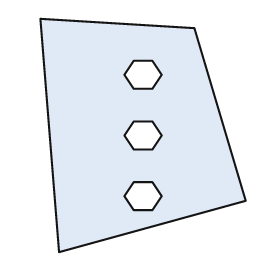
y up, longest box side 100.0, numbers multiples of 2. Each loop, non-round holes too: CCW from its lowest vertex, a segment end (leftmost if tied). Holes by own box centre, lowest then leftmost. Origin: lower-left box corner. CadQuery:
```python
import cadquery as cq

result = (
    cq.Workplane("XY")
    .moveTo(8.0, 0.0)
    .lineTo(88.0, 22.0)
    .lineTo(66.0, 96.0)
    .lineTo(0.0, 100.0)
    .close()
    .moveTo(40.0, 18.0)
    .lineTo(48.0, 18.0)
    .lineTo(52.0, 24.0)
    .lineTo(48.0, 30.0)
    .lineTo(40.0, 30.0)
    .lineTo(36.0, 24.0)
    .close()
    .moveTo(40.0, 44.0)
    .lineTo(48.0, 44.0)
    .lineTo(52.0, 50.0)
    .lineTo(48.0, 56.0)
    .lineTo(40.0, 56.0)
    .lineTo(36.0, 50.0)
    .close()
    .moveTo(40.0, 70.0)
    .lineTo(48.0, 70.0)
    .lineTo(52.0, 76.0)
    .lineTo(48.0, 82.0)
    .lineTo(40.0, 82.0)
    .lineTo(36.0, 76.0)
    .close()
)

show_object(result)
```